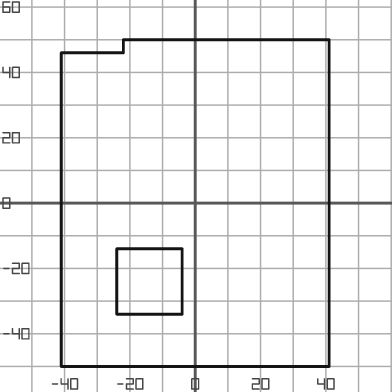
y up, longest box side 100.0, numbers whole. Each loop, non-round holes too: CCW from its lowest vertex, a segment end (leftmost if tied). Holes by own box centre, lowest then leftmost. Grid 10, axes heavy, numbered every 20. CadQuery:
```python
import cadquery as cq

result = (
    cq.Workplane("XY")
    .moveTo(-41.0, -50.0)
    .lineTo(41.0, -50.0)
    .lineTo(41.0, 50.0)
    .lineTo(-22.0, 50.0)
    .lineTo(-22.0, 46.0)
    .lineTo(-41.0, 46.0)
    .close()
    .moveTo(-24.0, -34.0)
    .lineTo(-4.0, -34.0)
    .lineTo(-4.0, -14.0)
    .lineTo(-24.0, -14.0)
    .close()
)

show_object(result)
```